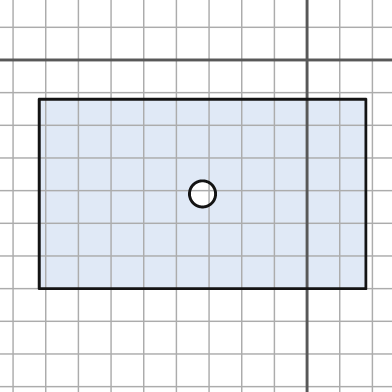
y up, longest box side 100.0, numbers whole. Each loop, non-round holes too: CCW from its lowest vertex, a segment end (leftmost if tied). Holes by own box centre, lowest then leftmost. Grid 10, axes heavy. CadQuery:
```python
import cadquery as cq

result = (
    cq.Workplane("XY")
    .moveTo(-82.0, -70.0)
    .lineTo(18.0, -70.0)
    .lineTo(18.0, -12.0)
    .lineTo(-82.0, -12.0)
    .close()
    .moveTo(-32.0, -41.0)
    .circle(4.0)
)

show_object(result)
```